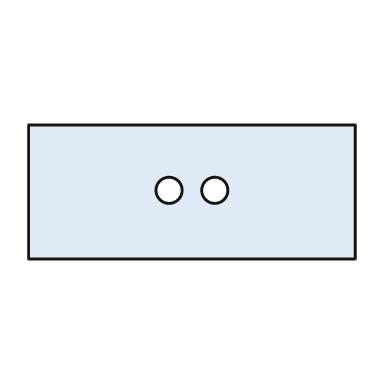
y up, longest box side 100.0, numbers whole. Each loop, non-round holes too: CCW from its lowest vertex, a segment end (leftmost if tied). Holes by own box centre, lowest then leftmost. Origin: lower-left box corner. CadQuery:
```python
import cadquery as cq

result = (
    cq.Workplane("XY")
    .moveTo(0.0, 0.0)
    .lineTo(100.0, 0.0)
    .lineTo(100.0, 41.0)
    .lineTo(0.0, 41.0)
    .close()
    .moveTo(43.0, 21.0)
    .circle(4.0)
    .moveTo(57.0, 21.0)
    .circle(4.0)
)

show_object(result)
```